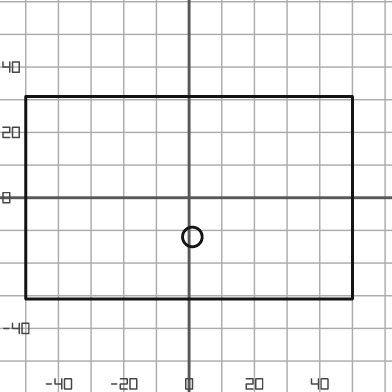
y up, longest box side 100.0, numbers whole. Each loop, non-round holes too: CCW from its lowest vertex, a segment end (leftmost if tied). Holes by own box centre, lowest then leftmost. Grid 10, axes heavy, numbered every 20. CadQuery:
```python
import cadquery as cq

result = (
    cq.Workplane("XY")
    .moveTo(-50.0, -31.0)
    .lineTo(50.0, -31.0)
    .lineTo(50.0, 31.0)
    .lineTo(-50.0, 31.0)
    .close()
    .moveTo(1.0, -12.0)
    .circle(3.0)
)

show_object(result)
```